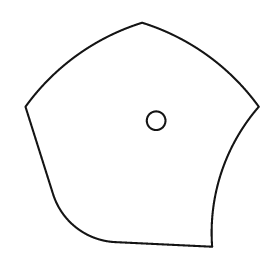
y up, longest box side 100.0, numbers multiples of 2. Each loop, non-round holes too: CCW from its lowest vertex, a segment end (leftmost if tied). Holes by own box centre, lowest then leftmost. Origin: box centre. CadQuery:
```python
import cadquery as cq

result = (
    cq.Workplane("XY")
    .moveTo(30.0, -48.0)
    .threePointArc((34.0, -16.0), (50.0, 12.0))
    .threePointArc((28.0, 34.0), (0.0, 48.0))
    .threePointArc((-28.0, 34.0), (-50.0, 12.0))
    .lineTo(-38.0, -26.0)
    .threePointArc((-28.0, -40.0), (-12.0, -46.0))
    .close()
    .moveTo(6.0, 6.0)
    .circle(4.0)
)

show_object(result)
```